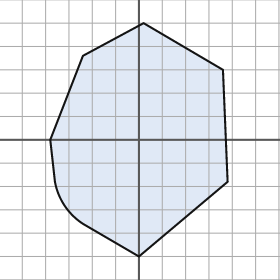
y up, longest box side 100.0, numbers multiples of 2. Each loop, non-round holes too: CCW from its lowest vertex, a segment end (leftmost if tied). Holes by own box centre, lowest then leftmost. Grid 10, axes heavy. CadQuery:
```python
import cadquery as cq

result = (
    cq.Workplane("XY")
    .moveTo(0.0, -50.0)
    .lineTo(38.0, -18.0)
    .lineTo(36.0, 30.0)
    .lineTo(2.0, 50.0)
    .lineTo(-24.0, 36.0)
    .lineTo(-38.0, 0.0)
    .lineTo(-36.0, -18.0)
    .threePointArc((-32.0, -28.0), (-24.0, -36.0))
    .close()
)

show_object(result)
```